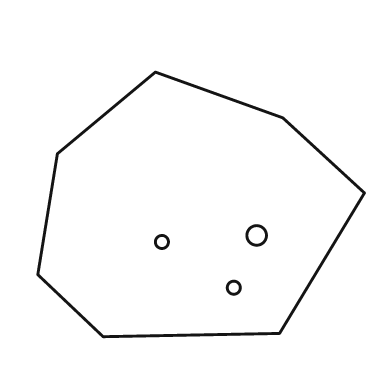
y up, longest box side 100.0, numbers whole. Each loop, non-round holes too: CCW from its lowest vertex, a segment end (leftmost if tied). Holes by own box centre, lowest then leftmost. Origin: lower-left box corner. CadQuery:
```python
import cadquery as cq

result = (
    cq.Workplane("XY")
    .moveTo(20.0, 0.0)
    .lineTo(74.0, 1.0)
    .lineTo(100.0, 44.0)
    .lineTo(75.0, 67.0)
    .lineTo(36.0, 81.0)
    .lineTo(6.0, 56.0)
    .lineTo(0.0, 19.0)
    .close()
    .moveTo(60.0, 15.0)
    .circle(2.0)
    .moveTo(38.0, 29.0)
    .circle(2.0)
    .moveTo(67.0, 31.0)
    .circle(3.0)
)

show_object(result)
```